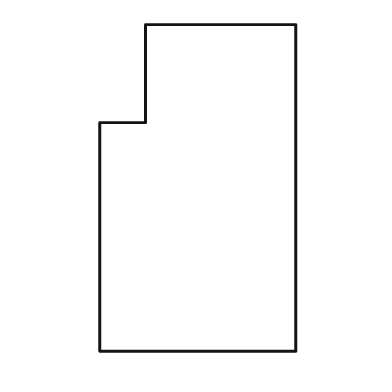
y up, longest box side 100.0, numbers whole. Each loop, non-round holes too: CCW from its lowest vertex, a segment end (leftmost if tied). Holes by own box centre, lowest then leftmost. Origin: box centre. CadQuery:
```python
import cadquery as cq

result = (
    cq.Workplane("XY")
    .moveTo(-30.0, -50.0)
    .lineTo(30.0, -50.0)
    .lineTo(30.0, 50.0)
    .lineTo(-16.0, 50.0)
    .lineTo(-16.0, 20.0)
    .lineTo(-30.0, 20.0)
    .close()
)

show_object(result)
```